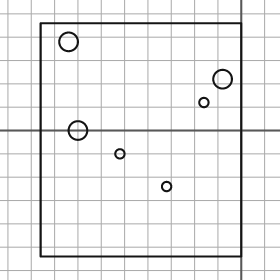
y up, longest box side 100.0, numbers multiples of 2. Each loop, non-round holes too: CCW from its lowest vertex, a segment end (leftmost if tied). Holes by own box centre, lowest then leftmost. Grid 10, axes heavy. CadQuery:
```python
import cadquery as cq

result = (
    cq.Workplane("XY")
    .moveTo(-86.0, -54.0)
    .lineTo(0.0, -54.0)
    .lineTo(0.0, 46.0)
    .lineTo(-86.0, 46.0)
    .close()
    .moveTo(-32.0, -24.0)
    .circle(2.0)
    .moveTo(-52.0, -10.0)
    .circle(2.0)
    .moveTo(-70.0, 0.0)
    .circle(4.0)
    .moveTo(-16.0, 12.0)
    .circle(2.0)
    .moveTo(-8.0, 22.0)
    .circle(4.0)
    .moveTo(-74.0, 38.0)
    .circle(4.0)
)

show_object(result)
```